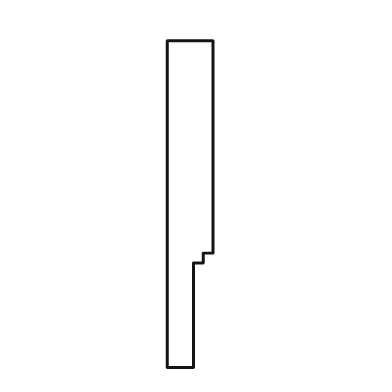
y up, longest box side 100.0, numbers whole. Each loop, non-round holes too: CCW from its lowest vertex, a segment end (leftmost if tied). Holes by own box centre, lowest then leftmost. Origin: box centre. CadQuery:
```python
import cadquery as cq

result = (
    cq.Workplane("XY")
    .moveTo(-7.0, -50.0)
    .lineTo(1.0, -50.0)
    .lineTo(1.0, -18.0)
    .lineTo(4.0, -18.0)
    .lineTo(4.0, -15.0)
    .lineTo(7.0, -15.0)
    .lineTo(7.0, 50.0)
    .lineTo(-7.0, 50.0)
    .close()
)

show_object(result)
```